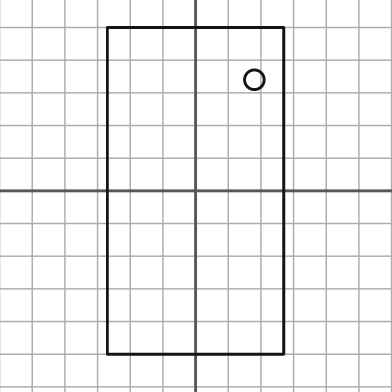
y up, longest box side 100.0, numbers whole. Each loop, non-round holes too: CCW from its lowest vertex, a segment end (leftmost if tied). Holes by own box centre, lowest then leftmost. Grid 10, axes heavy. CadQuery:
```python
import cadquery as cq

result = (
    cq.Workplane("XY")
    .moveTo(-27.0, -50.0)
    .lineTo(27.0, -50.0)
    .lineTo(27.0, 50.0)
    .lineTo(-27.0, 50.0)
    .close()
    .moveTo(18.0, 34.0)
    .circle(3.0)
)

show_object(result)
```